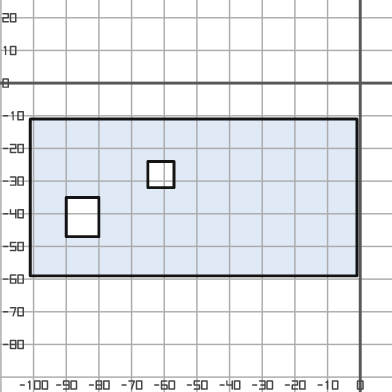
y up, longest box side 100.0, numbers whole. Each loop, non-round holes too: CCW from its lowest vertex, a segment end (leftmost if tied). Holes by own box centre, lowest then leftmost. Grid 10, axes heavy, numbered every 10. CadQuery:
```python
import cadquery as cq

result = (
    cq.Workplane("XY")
    .moveTo(-101.0, -59.0)
    .lineTo(-1.0, -59.0)
    .lineTo(-1.0, -11.0)
    .lineTo(-101.0, -11.0)
    .close()
    .moveTo(-90.0, -47.0)
    .lineTo(-80.0, -47.0)
    .lineTo(-80.0, -35.0)
    .lineTo(-90.0, -35.0)
    .close()
    .moveTo(-65.0, -32.0)
    .lineTo(-57.0, -32.0)
    .lineTo(-57.0, -24.0)
    .lineTo(-65.0, -24.0)
    .close()
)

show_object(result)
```